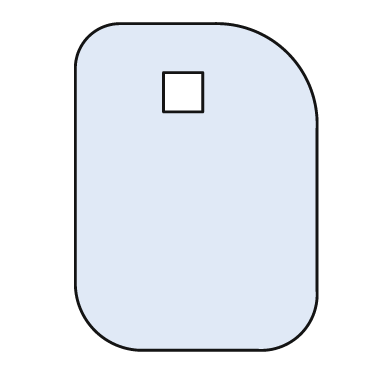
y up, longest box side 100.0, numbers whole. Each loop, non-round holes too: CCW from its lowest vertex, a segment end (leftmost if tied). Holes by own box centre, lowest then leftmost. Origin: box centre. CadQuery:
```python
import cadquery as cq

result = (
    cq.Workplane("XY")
    .moveTo(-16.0, -50.0)
    .lineTo(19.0, -50.0)
    .threePointArc((32.0, -45.0), (37.0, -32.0))
    .lineTo(37.0, 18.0)
    .threePointArc((28.0, 41.0), (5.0, 50.0))
    .lineTo(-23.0, 50.0)
    .threePointArc((-33.0, 46.0), (-37.0, 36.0))
    .lineTo(-37.0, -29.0)
    .threePointArc((-31.0, -44.0), (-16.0, -50.0))
    .close()
    .moveTo(-10.0, 23.0)
    .lineTo(2.0, 23.0)
    .lineTo(2.0, 35.0)
    .lineTo(-10.0, 35.0)
    .close()
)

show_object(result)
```